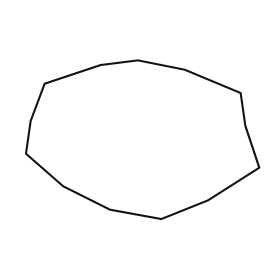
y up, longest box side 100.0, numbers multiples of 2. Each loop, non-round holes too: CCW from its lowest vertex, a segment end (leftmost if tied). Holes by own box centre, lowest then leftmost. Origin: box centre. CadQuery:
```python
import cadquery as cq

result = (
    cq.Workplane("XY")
    .moveTo(8.0, -34.0)
    .lineTo(28.0, -26.0)
    .lineTo(50.0, -12.0)
    .lineTo(44.0, 6.0)
    .lineTo(42.0, 20.0)
    .lineTo(18.0, 30.0)
    .lineTo(-2.0, 34.0)
    .lineTo(-18.0, 32.0)
    .lineTo(-42.0, 24.0)
    .lineTo(-48.0, 8.0)
    .lineTo(-50.0, -6.0)
    .lineTo(-34.0, -20.0)
    .lineTo(-14.0, -30.0)
    .close()
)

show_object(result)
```